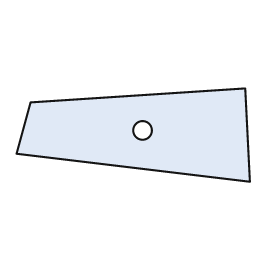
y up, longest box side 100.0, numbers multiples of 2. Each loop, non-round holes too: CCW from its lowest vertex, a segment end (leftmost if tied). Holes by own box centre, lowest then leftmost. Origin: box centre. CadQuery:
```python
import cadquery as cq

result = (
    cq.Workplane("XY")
    .moveTo(50.0, -20.0)
    .lineTo(48.0, 20.0)
    .lineTo(-44.0, 14.0)
    .lineTo(-50.0, -8.0)
    .close()
    .moveTo(4.0, 2.0)
    .circle(4.0)
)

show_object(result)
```